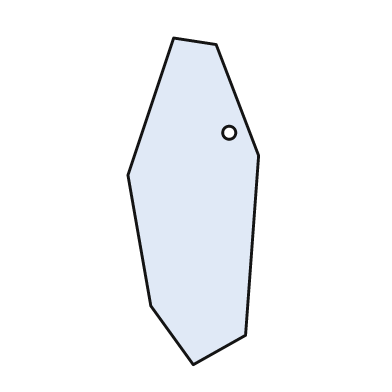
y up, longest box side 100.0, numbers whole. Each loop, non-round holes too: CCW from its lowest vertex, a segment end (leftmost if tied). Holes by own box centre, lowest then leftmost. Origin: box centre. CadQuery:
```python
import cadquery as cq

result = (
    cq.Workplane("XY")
    .moveTo(0.0, -50.0)
    .lineTo(16.0, -41.0)
    .lineTo(20.0, 14.0)
    .lineTo(7.0, 48.0)
    .lineTo(-6.0, 50.0)
    .lineTo(-20.0, 8.0)
    .lineTo(-13.0, -32.0)
    .close()
    .moveTo(11.0, 21.0)
    .circle(2.0)
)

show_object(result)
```